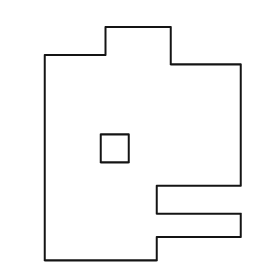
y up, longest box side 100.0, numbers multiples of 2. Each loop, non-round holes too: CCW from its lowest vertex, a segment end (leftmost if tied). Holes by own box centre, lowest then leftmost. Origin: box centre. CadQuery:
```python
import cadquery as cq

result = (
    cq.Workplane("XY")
    .moveTo(-42.0, -50.0)
    .lineTo(6.0, -50.0)
    .lineTo(6.0, -40.0)
    .lineTo(42.0, -40.0)
    .lineTo(42.0, -30.0)
    .lineTo(6.0, -30.0)
    .lineTo(6.0, -18.0)
    .lineTo(42.0, -18.0)
    .lineTo(42.0, 34.0)
    .lineTo(12.0, 34.0)
    .lineTo(12.0, 50.0)
    .lineTo(-16.0, 50.0)
    .lineTo(-16.0, 38.0)
    .lineTo(-42.0, 38.0)
    .close()
    .moveTo(-18.0, -8.0)
    .lineTo(-6.0, -8.0)
    .lineTo(-6.0, 4.0)
    .lineTo(-18.0, 4.0)
    .close()
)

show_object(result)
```